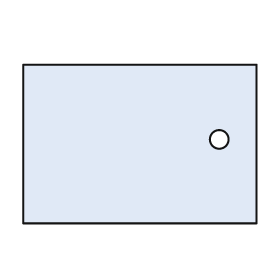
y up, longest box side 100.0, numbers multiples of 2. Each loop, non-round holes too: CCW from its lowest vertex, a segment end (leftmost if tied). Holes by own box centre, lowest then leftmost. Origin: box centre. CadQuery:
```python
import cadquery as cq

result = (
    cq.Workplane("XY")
    .moveTo(-50.0, -34.0)
    .lineTo(50.0, -34.0)
    .lineTo(50.0, 34.0)
    .lineTo(-50.0, 34.0)
    .close()
    .moveTo(34.0, 2.0)
    .circle(4.0)
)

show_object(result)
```